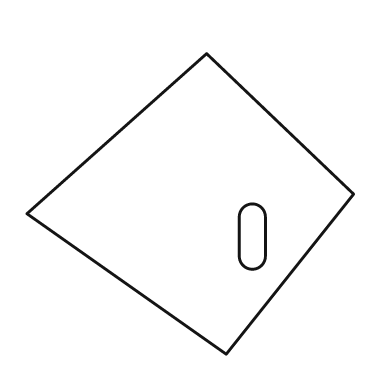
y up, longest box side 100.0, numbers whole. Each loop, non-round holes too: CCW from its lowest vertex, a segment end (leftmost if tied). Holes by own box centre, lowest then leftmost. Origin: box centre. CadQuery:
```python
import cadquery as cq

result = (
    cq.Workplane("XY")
    .moveTo(11.0, -46.0)
    .lineTo(50.0, 3.0)
    .lineTo(5.0, 46.0)
    .lineTo(-50.0, -3.0)
    .close()
    .moveTo(15.0, -16.0)
    .threePointArc((19.0, -20.0), (23.0, -16.0))
    .lineTo(23.0, -4.0)
    .threePointArc((19.0, 0.0), (15.0, -4.0))
    .close()
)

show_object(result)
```